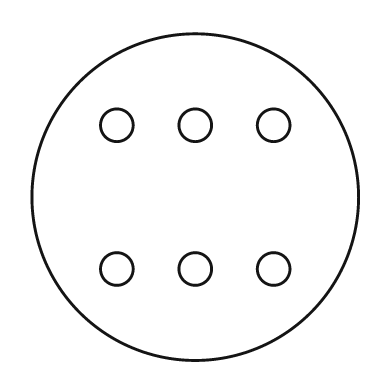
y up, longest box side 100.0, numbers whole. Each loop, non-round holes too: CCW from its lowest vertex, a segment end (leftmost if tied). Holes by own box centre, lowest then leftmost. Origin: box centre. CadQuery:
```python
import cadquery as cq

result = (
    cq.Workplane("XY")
    .moveTo(0.0, 0.0)
    .circle(50.0)
    .moveTo(-24.0, -22.0)
    .circle(5.0)
    .moveTo(0.0, -22.0)
    .circle(5.0)
    .moveTo(24.0, -22.0)
    .circle(5.0)
    .moveTo(-24.0, 22.0)
    .circle(5.0)
    .moveTo(0.0, 22.0)
    .circle(5.0)
    .moveTo(24.0, 22.0)
    .circle(5.0)
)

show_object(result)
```